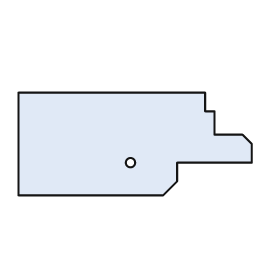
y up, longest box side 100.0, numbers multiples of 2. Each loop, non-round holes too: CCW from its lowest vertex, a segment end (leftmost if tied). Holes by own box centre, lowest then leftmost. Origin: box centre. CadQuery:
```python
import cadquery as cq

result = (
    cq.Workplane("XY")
    .moveTo(-50.0, -22.0)
    .lineTo(12.0, -22.0)
    .lineTo(18.0, -16.0)
    .lineTo(18.0, -8.0)
    .lineTo(50.0, -8.0)
    .lineTo(50.0, 0.0)
    .lineTo(46.0, 4.0)
    .lineTo(34.0, 4.0)
    .lineTo(34.0, 14.0)
    .lineTo(30.0, 14.0)
    .lineTo(30.0, 22.0)
    .lineTo(-50.0, 22.0)
    .close()
    .moveTo(-2.0, -8.0)
    .circle(2.0)
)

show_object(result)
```